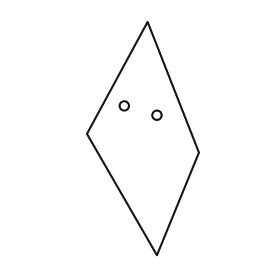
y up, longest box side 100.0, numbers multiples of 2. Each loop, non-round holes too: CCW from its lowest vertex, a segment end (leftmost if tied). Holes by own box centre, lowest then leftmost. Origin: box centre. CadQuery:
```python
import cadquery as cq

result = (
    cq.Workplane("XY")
    .moveTo(6.0, -50.0)
    .lineTo(24.0, -6.0)
    .lineTo(2.0, 50.0)
    .lineTo(-24.0, 2.0)
    .close()
    .moveTo(6.0, 10.0)
    .circle(2.0)
    .moveTo(-8.0, 14.0)
    .circle(2.0)
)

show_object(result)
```